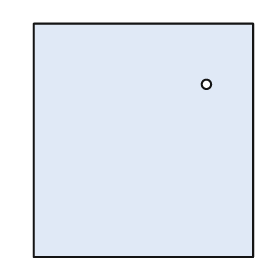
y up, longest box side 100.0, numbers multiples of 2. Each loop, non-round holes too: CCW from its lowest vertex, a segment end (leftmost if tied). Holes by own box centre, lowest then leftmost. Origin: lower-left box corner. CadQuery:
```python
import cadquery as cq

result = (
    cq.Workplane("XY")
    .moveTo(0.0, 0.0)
    .lineTo(94.0, 0.0)
    .lineTo(94.0, 100.0)
    .lineTo(0.0, 100.0)
    .close()
    .moveTo(74.0, 74.0)
    .circle(2.0)
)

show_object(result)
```